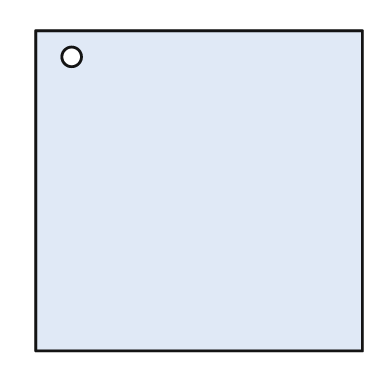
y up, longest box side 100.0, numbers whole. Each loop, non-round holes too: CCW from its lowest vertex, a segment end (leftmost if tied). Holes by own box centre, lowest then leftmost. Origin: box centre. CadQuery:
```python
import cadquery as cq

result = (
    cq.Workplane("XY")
    .moveTo(-50.0, -49.0)
    .lineTo(50.0, -49.0)
    .lineTo(50.0, 49.0)
    .lineTo(-50.0, 49.0)
    .close()
    .moveTo(-39.0, 41.0)
    .circle(3.0)
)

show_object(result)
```